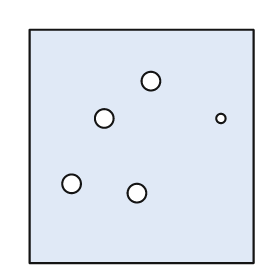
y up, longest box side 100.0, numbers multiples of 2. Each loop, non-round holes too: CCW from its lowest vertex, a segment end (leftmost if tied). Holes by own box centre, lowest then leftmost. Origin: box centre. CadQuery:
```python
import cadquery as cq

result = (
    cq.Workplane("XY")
    .moveTo(-48.0, -50.0)
    .lineTo(48.0, -50.0)
    .lineTo(48.0, 50.0)
    .lineTo(-48.0, 50.0)
    .close()
    .moveTo(-2.0, -20.0)
    .circle(4.0)
    .moveTo(-30.0, -16.0)
    .circle(4.0)
    .moveTo(-16.0, 12.0)
    .circle(4.0)
    .moveTo(34.0, 12.0)
    .circle(2.0)
    .moveTo(4.0, 28.0)
    .circle(4.0)
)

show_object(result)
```